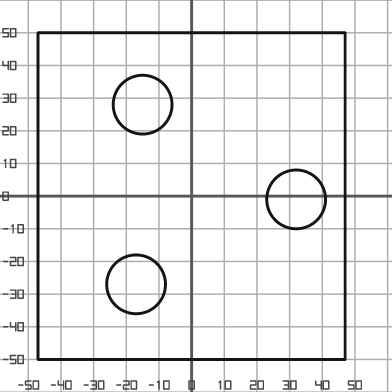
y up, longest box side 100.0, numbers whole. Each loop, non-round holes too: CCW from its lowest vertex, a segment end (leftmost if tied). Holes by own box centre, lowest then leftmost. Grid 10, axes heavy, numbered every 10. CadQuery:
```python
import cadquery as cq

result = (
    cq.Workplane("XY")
    .moveTo(-47.0, -50.0)
    .lineTo(47.0, -50.0)
    .lineTo(47.0, 50.0)
    .lineTo(-47.0, 50.0)
    .close()
    .moveTo(-17.0, -27.0)
    .circle(9.0)
    .moveTo(32.0, -1.0)
    .circle(9.0)
    .moveTo(-15.0, 28.0)
    .circle(9.0)
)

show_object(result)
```